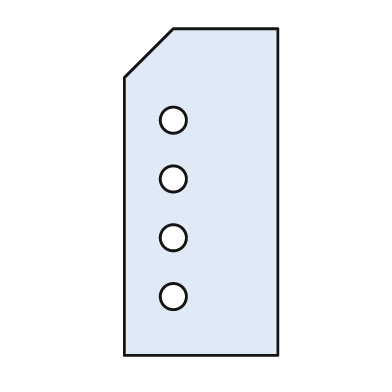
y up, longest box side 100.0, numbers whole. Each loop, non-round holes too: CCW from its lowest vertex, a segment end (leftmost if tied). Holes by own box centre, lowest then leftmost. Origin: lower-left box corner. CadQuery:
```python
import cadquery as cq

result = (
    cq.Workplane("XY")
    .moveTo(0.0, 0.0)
    .lineTo(47.0, 0.0)
    .lineTo(47.0, 100.0)
    .lineTo(15.0, 100.0)
    .lineTo(0.0, 85.0)
    .close()
    .moveTo(15.0, 18.0)
    .circle(4.0)
    .moveTo(15.0, 36.0)
    .circle(4.0)
    .moveTo(15.0, 54.0)
    .circle(4.0)
    .moveTo(15.0, 72.0)
    .circle(4.0)
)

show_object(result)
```